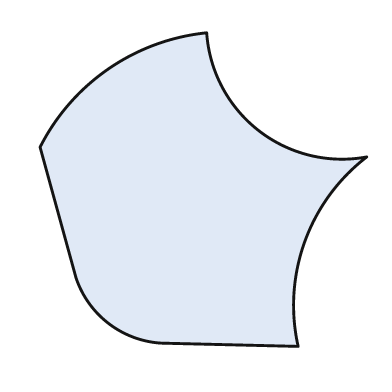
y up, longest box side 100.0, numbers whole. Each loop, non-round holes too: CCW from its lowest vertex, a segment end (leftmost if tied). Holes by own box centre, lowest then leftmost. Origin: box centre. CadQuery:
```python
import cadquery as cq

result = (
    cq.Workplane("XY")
    .moveTo(29.0, -48.0)
    .threePointArc((31.0, -16.0), (50.0, 10.0))
    .threePointArc((17.0, 18.0), (1.0, 48.0))
    .threePointArc((-29.0, 37.0), (-50.0, 13.0))
    .lineTo(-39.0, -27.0)
    .threePointArc((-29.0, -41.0), (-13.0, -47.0))
    .close()
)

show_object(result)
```